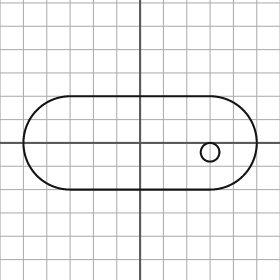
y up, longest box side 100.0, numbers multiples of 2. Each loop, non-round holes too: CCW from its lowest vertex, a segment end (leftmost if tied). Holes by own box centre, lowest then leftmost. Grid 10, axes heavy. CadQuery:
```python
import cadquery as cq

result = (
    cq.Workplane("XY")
    .moveTo(-30.0, -20.0)
    .lineTo(30.0, -20.0)
    .threePointArc((50.0, 0.0), (30.0, 20.0))
    .lineTo(-30.0, 20.0)
    .threePointArc((-50.0, 0.0), (-30.0, -20.0))
    .close()
    .moveTo(30.0, -4.0)
    .circle(4.0)
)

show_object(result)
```